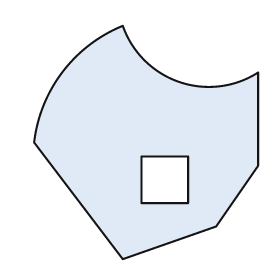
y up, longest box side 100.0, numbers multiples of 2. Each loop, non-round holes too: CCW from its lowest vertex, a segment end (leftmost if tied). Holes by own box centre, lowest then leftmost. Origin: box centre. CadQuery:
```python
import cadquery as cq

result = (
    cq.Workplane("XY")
    .moveTo(-10.0, -50.0)
    .lineTo(30.0, -36.0)
    .lineTo(48.0, -10.0)
    .lineTo(48.0, 30.0)
    .threePointArc((14.0, 26.0), (-10.0, 50.0))
    .threePointArc((-36.0, 30.0), (-48.0, 0.0))
    .close()
    .moveTo(-2.0, -26.0)
    .lineTo(18.0, -26.0)
    .lineTo(18.0, -6.0)
    .lineTo(-2.0, -6.0)
    .close()
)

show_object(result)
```